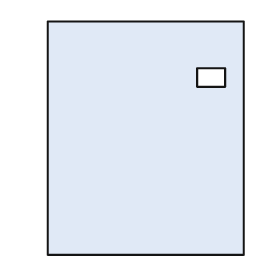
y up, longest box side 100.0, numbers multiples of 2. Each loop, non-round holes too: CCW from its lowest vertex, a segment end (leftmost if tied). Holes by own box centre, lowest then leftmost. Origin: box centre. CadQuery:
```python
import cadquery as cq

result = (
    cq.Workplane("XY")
    .moveTo(-42.0, -50.0)
    .lineTo(42.0, -50.0)
    .lineTo(42.0, 50.0)
    .lineTo(-42.0, 50.0)
    .close()
    .moveTo(22.0, 22.0)
    .lineTo(34.0, 22.0)
    .lineTo(34.0, 30.0)
    .lineTo(22.0, 30.0)
    .close()
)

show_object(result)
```